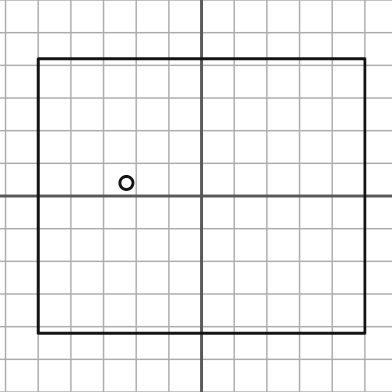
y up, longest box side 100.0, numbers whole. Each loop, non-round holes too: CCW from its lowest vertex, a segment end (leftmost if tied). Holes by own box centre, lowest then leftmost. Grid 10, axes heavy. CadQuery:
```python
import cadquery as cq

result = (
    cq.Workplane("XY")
    .moveTo(-50.0, -42.0)
    .lineTo(50.0, -42.0)
    .lineTo(50.0, 42.0)
    .lineTo(-50.0, 42.0)
    .close()
    .moveTo(-23.0, 4.0)
    .circle(2.0)
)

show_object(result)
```